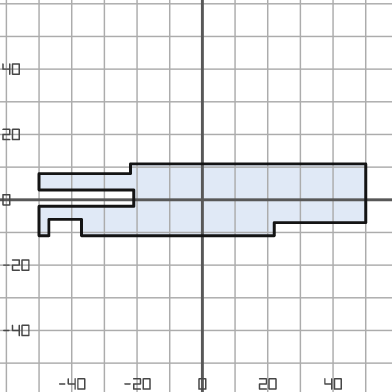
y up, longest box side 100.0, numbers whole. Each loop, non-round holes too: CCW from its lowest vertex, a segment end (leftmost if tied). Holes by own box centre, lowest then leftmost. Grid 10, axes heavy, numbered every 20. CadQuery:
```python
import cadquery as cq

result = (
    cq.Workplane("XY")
    .moveTo(-50.0, -11.0)
    .lineTo(-47.0, -11.0)
    .lineTo(-47.0, -6.0)
    .lineTo(-37.0, -6.0)
    .lineTo(-37.0, -11.0)
    .lineTo(22.0, -11.0)
    .lineTo(22.0, -7.0)
    .lineTo(50.0, -7.0)
    .lineTo(50.0, 11.0)
    .lineTo(-22.0, 11.0)
    .lineTo(-22.0, 8.0)
    .lineTo(-50.0, 8.0)
    .lineTo(-50.0, 3.0)
    .lineTo(-21.0, 3.0)
    .lineTo(-21.0, -2.0)
    .lineTo(-50.0, -2.0)
    .close()
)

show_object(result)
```